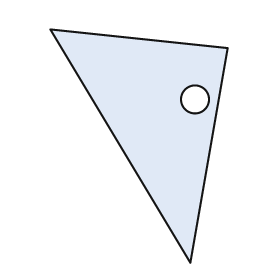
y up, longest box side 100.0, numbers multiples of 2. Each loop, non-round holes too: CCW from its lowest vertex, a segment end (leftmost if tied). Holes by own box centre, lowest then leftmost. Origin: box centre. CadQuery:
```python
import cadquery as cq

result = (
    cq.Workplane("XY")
    .moveTo(22.0, -50.0)
    .lineTo(38.0, 42.0)
    .lineTo(-38.0, 50.0)
    .close()
    .moveTo(24.0, 20.0)
    .circle(6.0)
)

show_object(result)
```